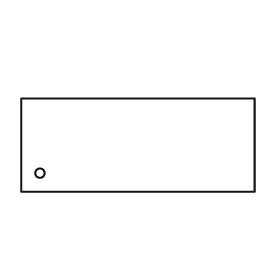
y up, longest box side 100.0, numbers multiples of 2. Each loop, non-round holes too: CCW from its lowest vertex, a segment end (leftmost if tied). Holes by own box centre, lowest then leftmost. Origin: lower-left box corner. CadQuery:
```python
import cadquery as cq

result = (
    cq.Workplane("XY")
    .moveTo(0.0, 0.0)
    .lineTo(100.0, 0.0)
    .lineTo(100.0, 40.0)
    .lineTo(0.0, 40.0)
    .close()
    .moveTo(8.0, 8.0)
    .circle(2.0)
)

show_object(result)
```